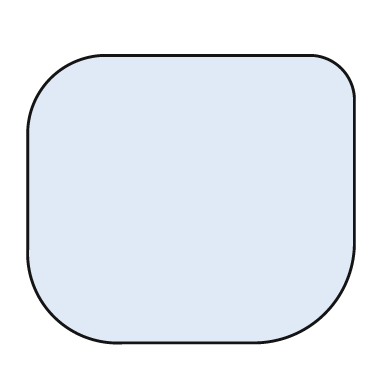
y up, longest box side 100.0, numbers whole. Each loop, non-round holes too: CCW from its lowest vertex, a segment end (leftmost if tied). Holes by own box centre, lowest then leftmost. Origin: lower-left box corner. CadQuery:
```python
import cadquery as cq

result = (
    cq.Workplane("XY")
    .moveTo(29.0, 0.0)
    .lineTo(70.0, 0.0)
    .threePointArc((91.0, 9.0), (100.0, 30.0))
    .lineTo(100.0, 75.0)
    .threePointArc((96.0, 84.0), (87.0, 88.0))
    .lineTo(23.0, 88.0)
    .threePointArc((7.0, 81.0), (0.0, 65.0))
    .lineTo(0.0, 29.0)
    .threePointArc((8.0, 8.0), (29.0, 0.0))
    .close()
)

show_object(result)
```